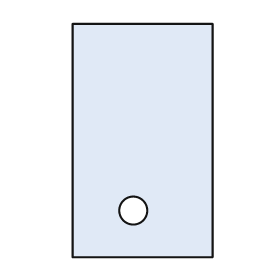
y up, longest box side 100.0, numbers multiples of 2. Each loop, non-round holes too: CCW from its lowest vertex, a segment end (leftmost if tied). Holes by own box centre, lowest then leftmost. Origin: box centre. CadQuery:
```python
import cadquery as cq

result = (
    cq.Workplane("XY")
    .moveTo(-30.0, -50.0)
    .lineTo(30.0, -50.0)
    .lineTo(30.0, 50.0)
    .lineTo(-30.0, 50.0)
    .close()
    .moveTo(-4.0, -30.0)
    .circle(6.0)
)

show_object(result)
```